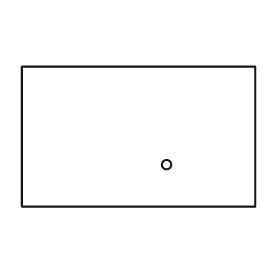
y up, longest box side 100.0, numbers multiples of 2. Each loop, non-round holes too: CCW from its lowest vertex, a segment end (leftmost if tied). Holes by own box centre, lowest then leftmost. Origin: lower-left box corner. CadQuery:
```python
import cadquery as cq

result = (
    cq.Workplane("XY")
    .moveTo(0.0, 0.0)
    .lineTo(100.0, 0.0)
    .lineTo(100.0, 60.0)
    .lineTo(0.0, 60.0)
    .close()
    .moveTo(62.0, 18.0)
    .circle(2.0)
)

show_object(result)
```